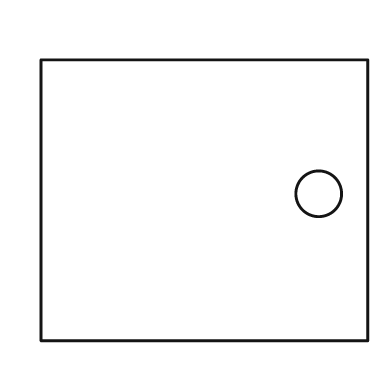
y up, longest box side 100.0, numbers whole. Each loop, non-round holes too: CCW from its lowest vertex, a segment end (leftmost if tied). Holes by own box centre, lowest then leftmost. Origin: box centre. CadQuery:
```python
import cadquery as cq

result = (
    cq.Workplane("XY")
    .moveTo(-50.0, -43.0)
    .lineTo(50.0, -43.0)
    .lineTo(50.0, 43.0)
    .lineTo(-50.0, 43.0)
    .close()
    .moveTo(35.0, 2.0)
    .circle(7.0)
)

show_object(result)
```